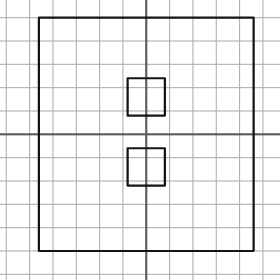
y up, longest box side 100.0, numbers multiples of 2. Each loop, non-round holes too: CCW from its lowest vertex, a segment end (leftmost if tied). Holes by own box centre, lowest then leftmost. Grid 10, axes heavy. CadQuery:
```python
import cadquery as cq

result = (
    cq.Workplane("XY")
    .moveTo(-46.0, -50.0)
    .lineTo(46.0, -50.0)
    .lineTo(46.0, 50.0)
    .lineTo(-46.0, 50.0)
    .close()
    .moveTo(-8.0, -22.0)
    .lineTo(8.0, -22.0)
    .lineTo(8.0, -6.0)
    .lineTo(-8.0, -6.0)
    .close()
    .moveTo(-8.0, 8.0)
    .lineTo(8.0, 8.0)
    .lineTo(8.0, 24.0)
    .lineTo(-8.0, 24.0)
    .close()
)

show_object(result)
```